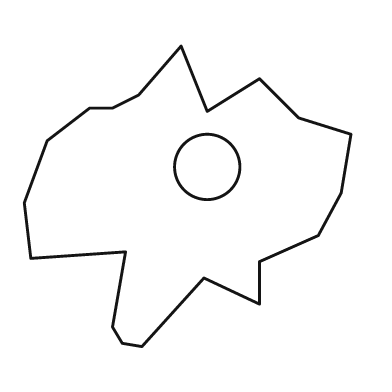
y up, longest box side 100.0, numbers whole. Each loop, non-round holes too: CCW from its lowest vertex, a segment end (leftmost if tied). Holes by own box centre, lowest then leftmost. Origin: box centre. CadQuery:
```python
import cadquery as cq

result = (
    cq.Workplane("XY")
    .moveTo(-14.0, -46.0)
    .lineTo(5.0, -25.0)
    .lineTo(22.0, -33.0)
    .lineTo(22.0, -20.0)
    .lineTo(40.0, -12.0)
    .lineTo(47.0, 1.0)
    .lineTo(50.0, 19.0)
    .lineTo(34.0, 24.0)
    .lineTo(22.0, 36.0)
    .lineTo(6.0, 26.0)
    .lineTo(-2.0, 46.0)
    .lineTo(-15.0, 31.0)
    .lineTo(-23.0, 27.0)
    .lineTo(-30.0, 27.0)
    .lineTo(-43.0, 17.0)
    .lineTo(-50.0, -2.0)
    .lineTo(-48.0, -19.0)
    .lineTo(-19.0, -17.0)
    .lineTo(-23.0, -40.0)
    .lineTo(-20.0, -45.0)
    .close()
    .moveTo(6.0, 9.0)
    .circle(10.0)
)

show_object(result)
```